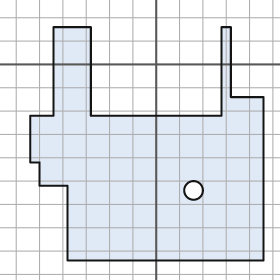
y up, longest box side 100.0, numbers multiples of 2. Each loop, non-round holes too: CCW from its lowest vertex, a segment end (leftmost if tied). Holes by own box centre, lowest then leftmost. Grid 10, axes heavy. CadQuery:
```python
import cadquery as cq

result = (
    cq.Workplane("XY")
    .moveTo(-38.0, -84.0)
    .lineTo(46.0, -84.0)
    .lineTo(46.0, -14.0)
    .lineTo(32.0, -14.0)
    .lineTo(32.0, 16.0)
    .lineTo(28.0, 16.0)
    .lineTo(28.0, -22.0)
    .lineTo(-28.0, -22.0)
    .lineTo(-28.0, 16.0)
    .lineTo(-44.0, 16.0)
    .lineTo(-44.0, -22.0)
    .lineTo(-54.0, -22.0)
    .lineTo(-54.0, -42.0)
    .lineTo(-50.0, -42.0)
    .lineTo(-50.0, -52.0)
    .lineTo(-38.0, -52.0)
    .close()
    .moveTo(16.0, -54.0)
    .circle(4.0)
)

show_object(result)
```